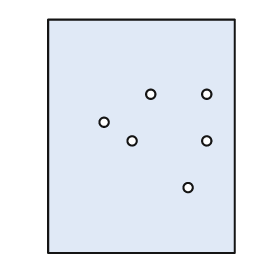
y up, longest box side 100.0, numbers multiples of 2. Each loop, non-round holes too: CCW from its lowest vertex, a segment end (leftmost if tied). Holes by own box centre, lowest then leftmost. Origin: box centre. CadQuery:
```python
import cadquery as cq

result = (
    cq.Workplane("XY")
    .moveTo(-40.0, -50.0)
    .lineTo(40.0, -50.0)
    .lineTo(40.0, 50.0)
    .lineTo(-40.0, 50.0)
    .close()
    .moveTo(20.0, -22.0)
    .circle(2.0)
    .moveTo(-4.0, -2.0)
    .circle(2.0)
    .moveTo(28.0, -2.0)
    .circle(2.0)
    .moveTo(-16.0, 6.0)
    .circle(2.0)
    .moveTo(4.0, 18.0)
    .circle(2.0)
    .moveTo(28.0, 18.0)
    .circle(2.0)
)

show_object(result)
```